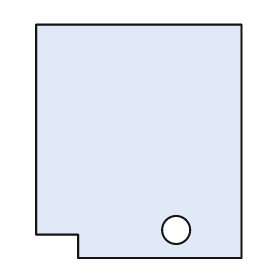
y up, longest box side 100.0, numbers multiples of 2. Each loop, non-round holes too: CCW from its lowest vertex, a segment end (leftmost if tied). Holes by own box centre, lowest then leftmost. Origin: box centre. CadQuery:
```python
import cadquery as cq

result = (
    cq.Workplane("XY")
    .moveTo(-26.0, -50.0)
    .lineTo(44.0, -50.0)
    .lineTo(44.0, 50.0)
    .lineTo(-44.0, 50.0)
    .lineTo(-44.0, -40.0)
    .lineTo(-26.0, -40.0)
    .close()
    .moveTo(16.0, -38.0)
    .circle(6.0)
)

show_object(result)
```